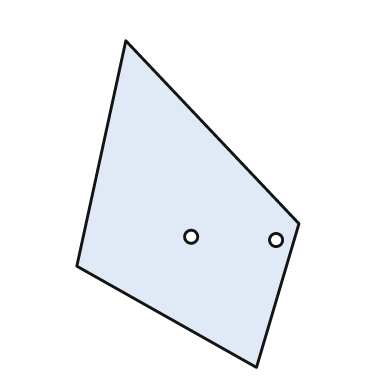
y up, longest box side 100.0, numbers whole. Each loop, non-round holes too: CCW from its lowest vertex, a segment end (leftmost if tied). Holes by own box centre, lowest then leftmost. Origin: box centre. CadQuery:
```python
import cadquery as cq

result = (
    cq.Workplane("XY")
    .moveTo(21.0, -50.0)
    .lineTo(34.0, -6.0)
    .lineTo(-19.0, 50.0)
    .lineTo(-34.0, -19.0)
    .close()
    .moveTo(27.0, -11.0)
    .circle(2.0)
    .moveTo(1.0, -10.0)
    .circle(2.0)
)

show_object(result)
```